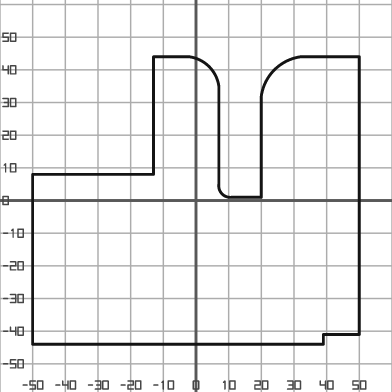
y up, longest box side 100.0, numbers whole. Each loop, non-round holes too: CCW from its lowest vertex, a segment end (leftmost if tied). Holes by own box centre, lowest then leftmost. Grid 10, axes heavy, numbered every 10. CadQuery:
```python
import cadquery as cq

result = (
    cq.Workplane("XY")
    .moveTo(-50.0, -44.0)
    .lineTo(39.0, -44.0)
    .lineTo(39.0, -41.0)
    .lineTo(50.0, -41.0)
    .lineTo(50.0, 44.0)
    .lineTo(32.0, 44.0)
    .threePointArc((24.0, 40.0), (20.0, 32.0))
    .lineTo(20.0, 1.0)
    .lineTo(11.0, 1.0)
    .threePointArc((8.0, 2.0), (7.0, 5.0))
    .lineTo(7.0, 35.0)
    .threePointArc((4.0, 41.0), (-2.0, 44.0))
    .lineTo(-13.0, 44.0)
    .lineTo(-13.0, 8.0)
    .lineTo(-50.0, 8.0)
    .close()
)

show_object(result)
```